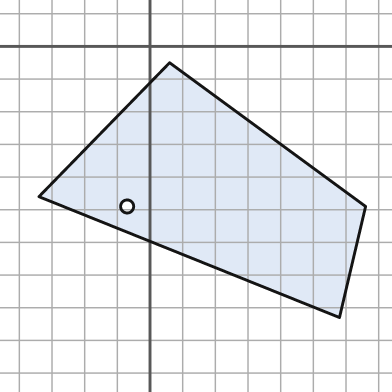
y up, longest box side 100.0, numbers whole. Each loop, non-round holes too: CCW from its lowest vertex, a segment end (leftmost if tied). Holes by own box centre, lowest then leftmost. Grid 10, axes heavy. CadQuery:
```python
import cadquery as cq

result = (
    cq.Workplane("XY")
    .moveTo(58.0, -83.0)
    .lineTo(66.0, -49.0)
    .lineTo(6.0, -5.0)
    .lineTo(-34.0, -46.0)
    .close()
    .moveTo(-7.0, -49.0)
    .circle(2.0)
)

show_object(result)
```